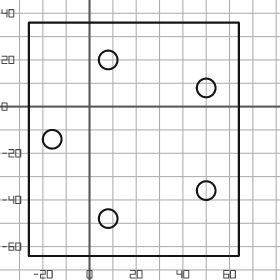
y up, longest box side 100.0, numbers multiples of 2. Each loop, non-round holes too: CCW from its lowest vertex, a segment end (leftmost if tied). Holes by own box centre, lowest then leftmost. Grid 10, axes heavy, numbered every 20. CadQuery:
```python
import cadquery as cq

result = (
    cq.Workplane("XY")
    .moveTo(-26.0, -64.0)
    .lineTo(64.0, -64.0)
    .lineTo(64.0, 36.0)
    .lineTo(-26.0, 36.0)
    .close()
    .moveTo(8.0, -48.0)
    .circle(4.0)
    .moveTo(50.0, -36.0)
    .circle(4.0)
    .moveTo(-16.0, -14.0)
    .circle(4.0)
    .moveTo(50.0, 8.0)
    .circle(4.0)
    .moveTo(8.0, 20.0)
    .circle(4.0)
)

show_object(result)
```